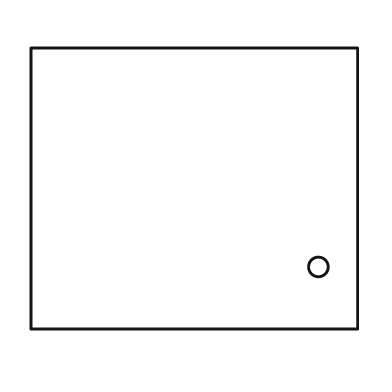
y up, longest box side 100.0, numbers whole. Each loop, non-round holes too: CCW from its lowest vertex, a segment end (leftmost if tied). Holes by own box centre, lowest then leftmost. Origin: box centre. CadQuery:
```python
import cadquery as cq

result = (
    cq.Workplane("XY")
    .moveTo(-50.0, -43.0)
    .lineTo(50.0, -43.0)
    .lineTo(50.0, 43.0)
    .lineTo(-50.0, 43.0)
    .close()
    .moveTo(38.0, -24.0)
    .circle(3.0)
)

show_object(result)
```